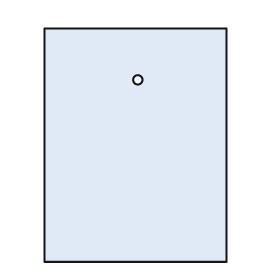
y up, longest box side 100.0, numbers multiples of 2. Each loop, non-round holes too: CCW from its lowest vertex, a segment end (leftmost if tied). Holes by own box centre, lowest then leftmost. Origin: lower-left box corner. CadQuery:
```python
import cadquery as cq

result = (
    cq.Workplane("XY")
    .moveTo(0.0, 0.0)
    .lineTo(78.0, 0.0)
    .lineTo(78.0, 100.0)
    .lineTo(0.0, 100.0)
    .close()
    .moveTo(40.0, 78.0)
    .circle(2.0)
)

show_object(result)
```